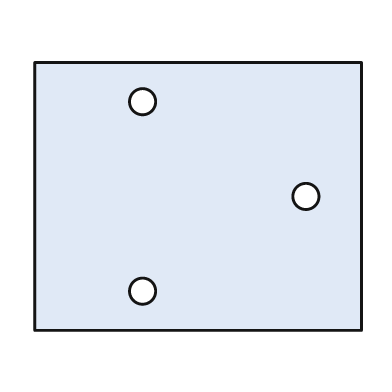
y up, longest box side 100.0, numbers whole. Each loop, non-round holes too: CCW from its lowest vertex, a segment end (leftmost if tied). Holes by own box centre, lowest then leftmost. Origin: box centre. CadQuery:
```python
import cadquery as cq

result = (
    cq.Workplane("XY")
    .moveTo(-50.0, -41.0)
    .lineTo(50.0, -41.0)
    .lineTo(50.0, 41.0)
    .lineTo(-50.0, 41.0)
    .close()
    .moveTo(-17.0, -29.0)
    .circle(4.0)
    .moveTo(33.0, 0.0)
    .circle(4.0)
    .moveTo(-17.0, 29.0)
    .circle(4.0)
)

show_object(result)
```